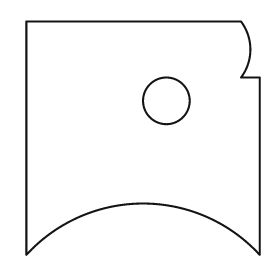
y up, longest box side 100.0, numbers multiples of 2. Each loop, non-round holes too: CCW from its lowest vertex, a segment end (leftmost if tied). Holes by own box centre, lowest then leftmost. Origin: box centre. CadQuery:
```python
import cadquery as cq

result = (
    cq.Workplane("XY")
    .moveTo(-50.0, -50.0)
    .threePointArc((0.0, -28.0), (50.0, -50.0))
    .lineTo(50.0, 26.0)
    .lineTo(42.0, 26.0)
    .threePointArc((46.0, 38.0), (42.0, 50.0))
    .lineTo(-50.0, 50.0)
    .close()
    .moveTo(10.0, 16.0)
    .circle(10.0)
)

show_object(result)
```